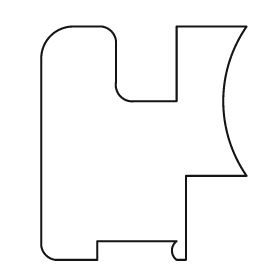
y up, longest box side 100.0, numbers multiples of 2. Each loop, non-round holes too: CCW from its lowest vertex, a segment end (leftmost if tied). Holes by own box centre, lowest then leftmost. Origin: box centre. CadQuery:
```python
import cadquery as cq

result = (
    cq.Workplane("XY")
    .moveTo(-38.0, -50.0)
    .lineTo(-20.0, -50.0)
    .lineTo(-20.0, -42.0)
    .lineTo(14.0, -42.0)
    .threePointArc((12.0, -46.0), (14.0, -50.0))
    .lineTo(18.0, -50.0)
    .lineTo(18.0, -14.0)
    .lineTo(44.0, -14.0)
    .threePointArc((34.0, 18.0), (44.0, 50.0))
    .lineTo(14.0, 50.0)
    .lineTo(14.0, 18.0)
    .lineTo(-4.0, 18.0)
    .threePointArc((-10.0, 20.0), (-12.0, 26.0))
    .lineTo(-12.0, 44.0)
    .threePointArc((-14.0, 48.0), (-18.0, 50.0))
    .lineTo(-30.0, 50.0)
    .threePointArc((-40.0, 46.0), (-44.0, 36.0))
    .lineTo(-44.0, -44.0)
    .threePointArc((-42.0, -48.0), (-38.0, -50.0))
    .close()
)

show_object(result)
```